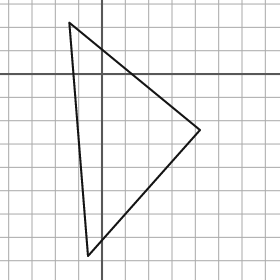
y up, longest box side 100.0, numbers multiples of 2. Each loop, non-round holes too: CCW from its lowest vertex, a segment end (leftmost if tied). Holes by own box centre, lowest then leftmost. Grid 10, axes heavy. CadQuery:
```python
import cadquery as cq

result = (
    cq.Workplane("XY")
    .moveTo(-6.0, -78.0)
    .lineTo(42.0, -24.0)
    .lineTo(-14.0, 22.0)
    .close()
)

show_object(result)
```